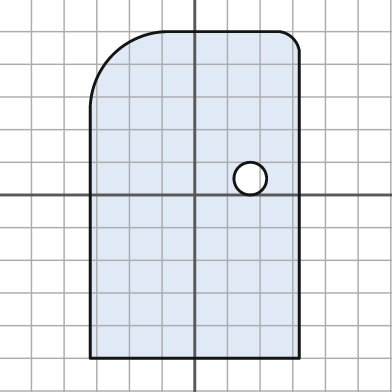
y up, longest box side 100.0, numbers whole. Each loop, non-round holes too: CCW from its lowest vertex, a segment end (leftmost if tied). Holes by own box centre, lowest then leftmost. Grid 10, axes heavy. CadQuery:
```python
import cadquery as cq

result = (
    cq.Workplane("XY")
    .moveTo(-32.0, -50.0)
    .lineTo(32.0, -50.0)
    .lineTo(32.0, 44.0)
    .threePointArc((30.0, 48.0), (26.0, 50.0))
    .lineTo(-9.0, 50.0)
    .threePointArc((-25.0, 43.0), (-32.0, 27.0))
    .close()
    .moveTo(17.0, 5.0)
    .circle(5.0)
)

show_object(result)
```